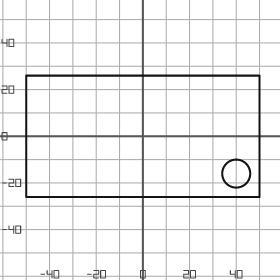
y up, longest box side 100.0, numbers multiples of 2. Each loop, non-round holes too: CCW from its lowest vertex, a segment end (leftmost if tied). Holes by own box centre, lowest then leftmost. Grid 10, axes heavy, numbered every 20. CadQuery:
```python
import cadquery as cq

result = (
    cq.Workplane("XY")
    .moveTo(-50.0, -26.0)
    .lineTo(50.0, -26.0)
    .lineTo(50.0, 26.0)
    .lineTo(-50.0, 26.0)
    .close()
    .moveTo(40.0, -16.0)
    .circle(6.0)
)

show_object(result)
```